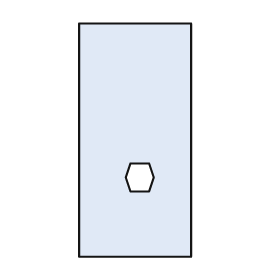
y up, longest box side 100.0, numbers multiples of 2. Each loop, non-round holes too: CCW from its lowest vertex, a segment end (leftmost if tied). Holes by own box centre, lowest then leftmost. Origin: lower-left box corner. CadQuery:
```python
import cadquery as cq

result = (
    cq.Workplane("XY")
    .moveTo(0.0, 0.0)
    .lineTo(48.0, 0.0)
    .lineTo(48.0, 100.0)
    .lineTo(0.0, 100.0)
    .close()
    .moveTo(22.0, 28.0)
    .lineTo(30.0, 28.0)
    .lineTo(32.0, 34.0)
    .lineTo(30.0, 40.0)
    .lineTo(22.0, 40.0)
    .lineTo(20.0, 34.0)
    .close()
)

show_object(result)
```